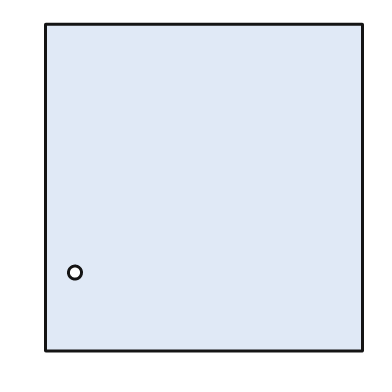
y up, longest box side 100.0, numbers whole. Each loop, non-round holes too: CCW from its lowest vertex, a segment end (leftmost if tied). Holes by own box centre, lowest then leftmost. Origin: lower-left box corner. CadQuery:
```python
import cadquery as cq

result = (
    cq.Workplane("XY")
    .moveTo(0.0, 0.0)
    .lineTo(97.0, 0.0)
    .lineTo(97.0, 100.0)
    .lineTo(0.0, 100.0)
    .close()
    .moveTo(9.0, 24.0)
    .circle(2.0)
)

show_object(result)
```